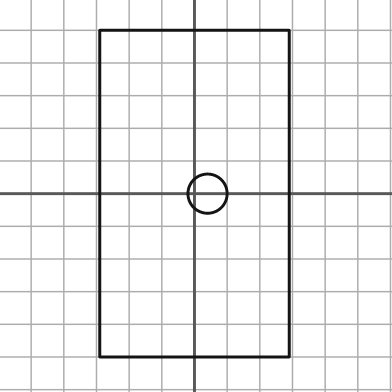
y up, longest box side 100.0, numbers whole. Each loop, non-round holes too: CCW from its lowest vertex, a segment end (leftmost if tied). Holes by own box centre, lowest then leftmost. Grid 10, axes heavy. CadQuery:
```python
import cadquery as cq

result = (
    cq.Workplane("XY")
    .moveTo(-29.0, -50.0)
    .lineTo(29.0, -50.0)
    .lineTo(29.0, 50.0)
    .lineTo(-29.0, 50.0)
    .close()
    .moveTo(4.0, 0.0)
    .circle(6.0)
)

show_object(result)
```